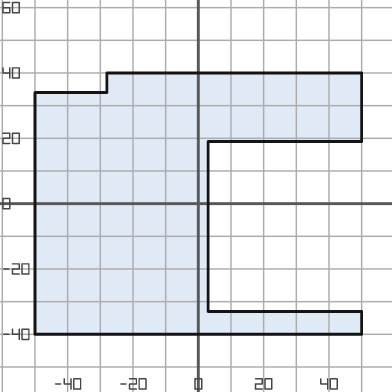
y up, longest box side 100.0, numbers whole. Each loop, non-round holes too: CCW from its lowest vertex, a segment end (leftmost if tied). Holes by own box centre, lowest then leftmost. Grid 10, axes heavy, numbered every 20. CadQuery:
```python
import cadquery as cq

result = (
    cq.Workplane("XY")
    .moveTo(-50.0, -40.0)
    .lineTo(50.0, -40.0)
    .lineTo(50.0, -33.0)
    .lineTo(3.0, -33.0)
    .lineTo(3.0, 19.0)
    .lineTo(50.0, 19.0)
    .lineTo(50.0, 40.0)
    .lineTo(-28.0, 40.0)
    .lineTo(-28.0, 34.0)
    .lineTo(-50.0, 34.0)
    .close()
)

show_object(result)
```